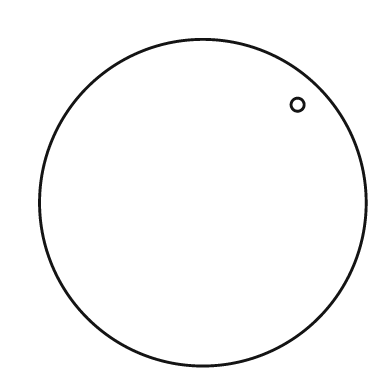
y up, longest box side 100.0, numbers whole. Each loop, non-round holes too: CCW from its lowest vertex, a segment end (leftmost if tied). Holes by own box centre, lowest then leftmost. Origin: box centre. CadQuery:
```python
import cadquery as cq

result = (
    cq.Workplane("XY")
    .moveTo(0.0, 0.0)
    .circle(50.0)
    .moveTo(29.0, 30.0)
    .circle(2.0)
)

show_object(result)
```